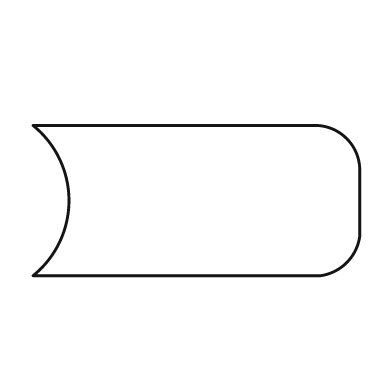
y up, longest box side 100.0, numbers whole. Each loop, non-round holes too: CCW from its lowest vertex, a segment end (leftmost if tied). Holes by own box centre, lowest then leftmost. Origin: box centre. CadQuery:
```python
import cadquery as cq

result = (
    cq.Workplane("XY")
    .moveTo(-50.0, -23.0)
    .lineTo(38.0, -23.0)
    .threePointArc((46.0, -19.0), (50.0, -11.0))
    .lineTo(50.0, 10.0)
    .threePointArc((46.0, 19.0), (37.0, 23.0))
    .lineTo(-50.0, 23.0)
    .threePointArc((-39.0, 0.0), (-50.0, -23.0))
    .close()
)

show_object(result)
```